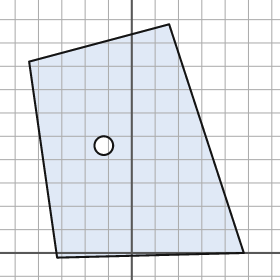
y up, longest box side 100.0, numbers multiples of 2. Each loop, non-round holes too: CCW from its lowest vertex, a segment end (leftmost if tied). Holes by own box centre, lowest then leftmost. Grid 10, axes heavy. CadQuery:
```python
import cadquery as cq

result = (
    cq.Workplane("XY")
    .moveTo(-32.0, -2.0)
    .lineTo(48.0, 0.0)
    .lineTo(16.0, 98.0)
    .lineTo(-44.0, 82.0)
    .close()
    .moveTo(-12.0, 46.0)
    .circle(4.0)
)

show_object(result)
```